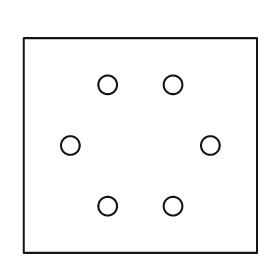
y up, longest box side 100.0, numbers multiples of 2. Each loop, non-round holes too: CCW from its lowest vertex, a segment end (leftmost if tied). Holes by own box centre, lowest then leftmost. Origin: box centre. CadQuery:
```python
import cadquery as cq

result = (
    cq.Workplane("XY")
    .moveTo(-50.0, -46.0)
    .lineTo(50.0, -46.0)
    .lineTo(50.0, 46.0)
    .lineTo(-50.0, 46.0)
    .close()
    .moveTo(-14.0, -26.0)
    .circle(4.0)
    .moveTo(14.0, -26.0)
    .circle(4.0)
    .moveTo(-30.0, 0.0)
    .circle(4.0)
    .moveTo(30.0, 0.0)
    .circle(4.0)
    .moveTo(-14.0, 26.0)
    .circle(4.0)
    .moveTo(14.0, 26.0)
    .circle(4.0)
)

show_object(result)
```